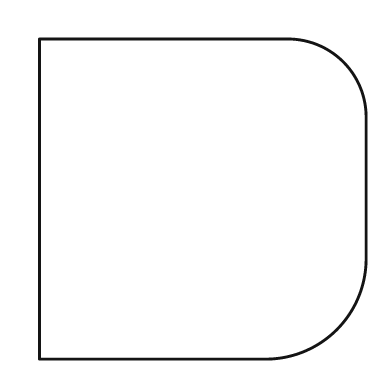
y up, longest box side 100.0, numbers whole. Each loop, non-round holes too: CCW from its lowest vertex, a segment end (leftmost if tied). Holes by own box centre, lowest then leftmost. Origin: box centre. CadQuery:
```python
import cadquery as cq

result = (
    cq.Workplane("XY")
    .moveTo(-50.0, -49.0)
    .lineTo(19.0, -49.0)
    .threePointArc((41.0, -40.0), (50.0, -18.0))
    .lineTo(50.0, 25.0)
    .threePointArc((43.0, 42.0), (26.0, 49.0))
    .lineTo(-50.0, 49.0)
    .close()
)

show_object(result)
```